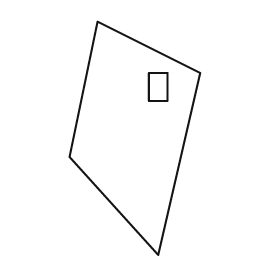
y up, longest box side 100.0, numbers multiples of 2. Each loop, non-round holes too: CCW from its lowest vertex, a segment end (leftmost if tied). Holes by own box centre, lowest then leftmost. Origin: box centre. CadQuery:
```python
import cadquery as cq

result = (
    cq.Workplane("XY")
    .moveTo(10.0, -50.0)
    .lineTo(28.0, 28.0)
    .lineTo(-16.0, 50.0)
    .lineTo(-28.0, -8.0)
    .close()
    .moveTo(6.0, 16.0)
    .lineTo(14.0, 16.0)
    .lineTo(14.0, 28.0)
    .lineTo(6.0, 28.0)
    .close()
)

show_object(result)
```